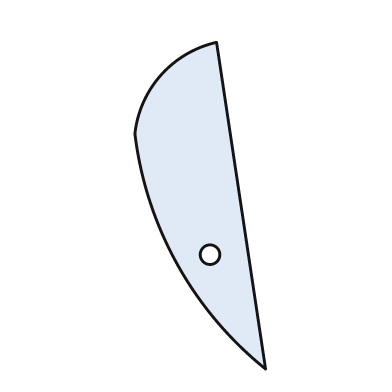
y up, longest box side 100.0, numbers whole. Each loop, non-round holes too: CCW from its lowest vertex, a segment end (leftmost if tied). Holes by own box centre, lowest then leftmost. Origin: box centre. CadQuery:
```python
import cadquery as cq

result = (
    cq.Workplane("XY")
    .moveTo(20.0, -50.0)
    .lineTo(5.0, 50.0)
    .threePointArc((-12.0, 40.0), (-20.0, 22.0))
    .threePointArc((-7.0, -18.0), (20.0, -50.0))
    .close()
    .moveTo(3.0, -15.0)
    .circle(3.0)
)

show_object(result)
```